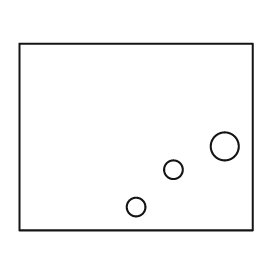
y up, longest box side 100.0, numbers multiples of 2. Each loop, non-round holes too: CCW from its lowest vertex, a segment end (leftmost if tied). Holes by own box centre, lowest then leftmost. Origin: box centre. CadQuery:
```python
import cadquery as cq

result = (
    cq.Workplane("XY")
    .moveTo(-50.0, -40.0)
    .lineTo(50.0, -40.0)
    .lineTo(50.0, 40.0)
    .lineTo(-50.0, 40.0)
    .close()
    .moveTo(0.0, -30.0)
    .circle(4.0)
    .moveTo(16.0, -14.0)
    .circle(4.0)
    .moveTo(38.0, -4.0)
    .circle(6.0)
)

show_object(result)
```